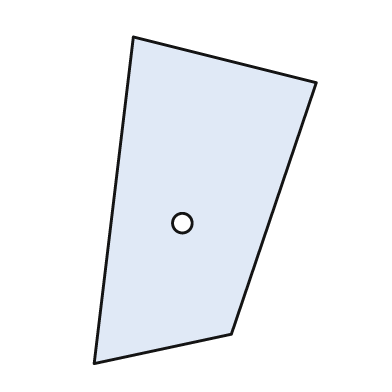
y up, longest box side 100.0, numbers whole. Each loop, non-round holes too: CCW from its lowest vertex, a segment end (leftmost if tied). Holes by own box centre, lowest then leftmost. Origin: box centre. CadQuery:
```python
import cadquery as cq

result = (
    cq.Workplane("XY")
    .moveTo(-34.0, -50.0)
    .lineTo(8.0, -41.0)
    .lineTo(34.0, 36.0)
    .lineTo(-22.0, 50.0)
    .close()
    .moveTo(-7.0, -7.0)
    .circle(3.0)
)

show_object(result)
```